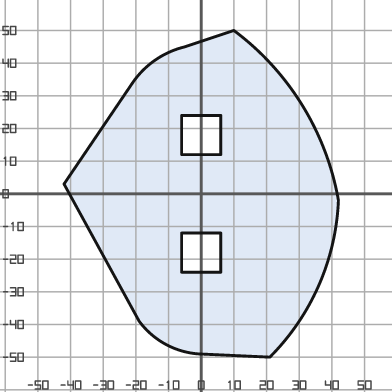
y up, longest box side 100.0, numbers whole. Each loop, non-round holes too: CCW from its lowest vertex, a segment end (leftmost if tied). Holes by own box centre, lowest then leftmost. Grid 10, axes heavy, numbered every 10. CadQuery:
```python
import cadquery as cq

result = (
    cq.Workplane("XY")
    .moveTo(21.0, -50.0)
    .threePointArc((36.0, -28.0), (42.0, -2.0))
    .threePointArc((31.0, 27.0), (10.0, 50.0))
    .lineTo(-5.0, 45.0)
    .threePointArc((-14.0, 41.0), (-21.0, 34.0))
    .lineTo(-42.0, 3.0)
    .lineTo(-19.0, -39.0)
    .threePointArc((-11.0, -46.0), (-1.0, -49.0))
    .close()
    .moveTo(-6.0, -24.0)
    .lineTo(6.0, -24.0)
    .lineTo(6.0, -12.0)
    .lineTo(-6.0, -12.0)
    .close()
    .moveTo(-6.0, 12.0)
    .lineTo(6.0, 12.0)
    .lineTo(6.0, 24.0)
    .lineTo(-6.0, 24.0)
    .close()
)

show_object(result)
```